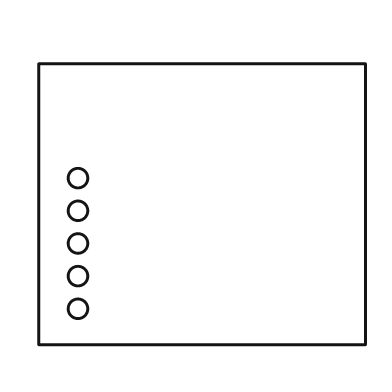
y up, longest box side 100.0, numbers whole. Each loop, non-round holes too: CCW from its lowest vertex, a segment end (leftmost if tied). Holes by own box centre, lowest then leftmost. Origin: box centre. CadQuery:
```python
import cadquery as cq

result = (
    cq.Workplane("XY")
    .moveTo(-50.0, -43.0)
    .lineTo(50.0, -43.0)
    .lineTo(50.0, 43.0)
    .lineTo(-50.0, 43.0)
    .close()
    .moveTo(-38.0, -32.0)
    .circle(3.0)
    .moveTo(-38.0, -22.0)
    .circle(3.0)
    .moveTo(-38.0, -12.0)
    .circle(3.0)
    .moveTo(-38.0, -2.0)
    .circle(3.0)
    .moveTo(-38.0, 8.0)
    .circle(3.0)
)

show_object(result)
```